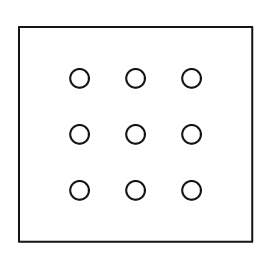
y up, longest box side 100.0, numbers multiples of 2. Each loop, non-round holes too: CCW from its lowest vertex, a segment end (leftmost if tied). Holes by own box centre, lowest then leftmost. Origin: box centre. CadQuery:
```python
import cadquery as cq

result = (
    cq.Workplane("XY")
    .moveTo(-50.0, -46.0)
    .lineTo(50.0, -46.0)
    .lineTo(50.0, 46.0)
    .lineTo(-50.0, 46.0)
    .close()
    .moveTo(-24.0, -24.0)
    .circle(4.0)
    .moveTo(0.0, -24.0)
    .circle(4.0)
    .moveTo(24.0, -24.0)
    .circle(4.0)
    .moveTo(-24.0, 0.0)
    .circle(4.0)
    .moveTo(0.0, 0.0)
    .circle(4.0)
    .moveTo(24.0, 0.0)
    .circle(4.0)
    .moveTo(-24.0, 24.0)
    .circle(4.0)
    .moveTo(0.0, 24.0)
    .circle(4.0)
    .moveTo(24.0, 24.0)
    .circle(4.0)
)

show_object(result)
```